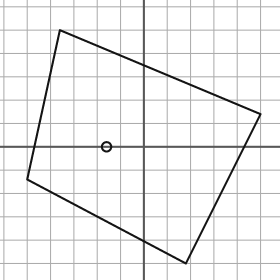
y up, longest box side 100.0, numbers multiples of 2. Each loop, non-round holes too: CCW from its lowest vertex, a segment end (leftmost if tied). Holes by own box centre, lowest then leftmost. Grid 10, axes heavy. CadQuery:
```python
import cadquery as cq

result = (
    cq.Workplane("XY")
    .moveTo(18.0, -50.0)
    .lineTo(50.0, 14.0)
    .lineTo(-36.0, 50.0)
    .lineTo(-50.0, -14.0)
    .close()
    .moveTo(-16.0, 0.0)
    .circle(2.0)
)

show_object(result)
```